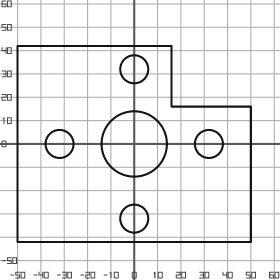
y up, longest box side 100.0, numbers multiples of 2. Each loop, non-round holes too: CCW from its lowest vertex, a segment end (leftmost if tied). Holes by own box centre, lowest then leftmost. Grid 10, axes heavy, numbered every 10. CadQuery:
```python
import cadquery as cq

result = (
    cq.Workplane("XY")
    .moveTo(-50.0, -42.0)
    .lineTo(50.0, -42.0)
    .lineTo(50.0, 16.0)
    .lineTo(16.0, 16.0)
    .lineTo(16.0, 42.0)
    .lineTo(-50.0, 42.0)
    .close()
    .moveTo(0.0, -32.0)
    .circle(6.0)
    .moveTo(-32.0, 0.0)
    .circle(6.0)
    .moveTo(0.0, 0.0)
    .circle(14.0)
    .moveTo(32.0, 0.0)
    .circle(6.0)
    .moveTo(0.0, 32.0)
    .circle(6.0)
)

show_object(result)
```